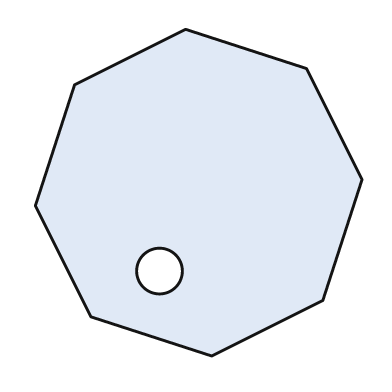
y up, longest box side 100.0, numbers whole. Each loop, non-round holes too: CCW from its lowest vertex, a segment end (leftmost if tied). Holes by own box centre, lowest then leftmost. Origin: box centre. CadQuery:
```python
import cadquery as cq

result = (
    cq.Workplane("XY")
    .moveTo(4.0, -50.0)
    .lineTo(38.0, -33.0)
    .lineTo(50.0, 4.0)
    .lineTo(33.0, 38.0)
    .lineTo(-4.0, 50.0)
    .lineTo(-38.0, 33.0)
    .lineTo(-50.0, -4.0)
    .lineTo(-33.0, -38.0)
    .close()
    .moveTo(-12.0, -24.0)
    .circle(7.0)
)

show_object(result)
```